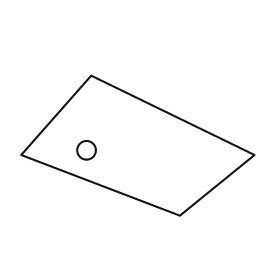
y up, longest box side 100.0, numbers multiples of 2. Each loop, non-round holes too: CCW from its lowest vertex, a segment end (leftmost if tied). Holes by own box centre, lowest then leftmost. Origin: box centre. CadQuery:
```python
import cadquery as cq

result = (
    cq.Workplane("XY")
    .moveTo(18.0, -30.0)
    .lineTo(50.0, -4.0)
    .lineTo(-20.0, 30.0)
    .lineTo(-50.0, -4.0)
    .close()
    .moveTo(-22.0, -2.0)
    .circle(4.0)
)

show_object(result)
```